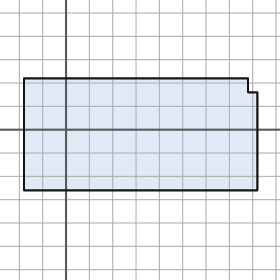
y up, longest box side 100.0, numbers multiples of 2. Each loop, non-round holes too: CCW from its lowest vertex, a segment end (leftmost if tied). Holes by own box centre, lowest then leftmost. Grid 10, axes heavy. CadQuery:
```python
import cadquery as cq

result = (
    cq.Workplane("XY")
    .moveTo(-18.0, -26.0)
    .lineTo(82.0, -26.0)
    .lineTo(82.0, 16.0)
    .lineTo(78.0, 16.0)
    .lineTo(78.0, 22.0)
    .lineTo(-18.0, 22.0)
    .close()
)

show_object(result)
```